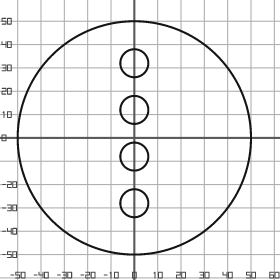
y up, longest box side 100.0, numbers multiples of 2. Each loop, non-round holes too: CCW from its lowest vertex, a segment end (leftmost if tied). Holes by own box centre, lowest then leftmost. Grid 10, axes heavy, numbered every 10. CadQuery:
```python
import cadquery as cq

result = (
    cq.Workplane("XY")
    .moveTo(0.0, 0.0)
    .circle(50.0)
    .moveTo(0.0, -28.0)
    .circle(6.0)
    .moveTo(0.0, -8.0)
    .circle(6.0)
    .moveTo(0.0, 12.0)
    .circle(6.0)
    .moveTo(0.0, 32.0)
    .circle(6.0)
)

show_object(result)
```